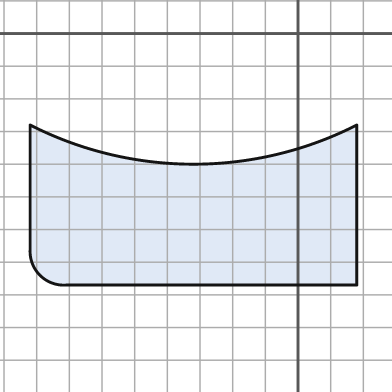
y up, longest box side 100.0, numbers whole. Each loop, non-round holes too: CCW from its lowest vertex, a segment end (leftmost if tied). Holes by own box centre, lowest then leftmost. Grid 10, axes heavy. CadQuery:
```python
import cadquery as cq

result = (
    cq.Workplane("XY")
    .moveTo(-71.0, -77.0)
    .lineTo(18.0, -77.0)
    .lineTo(18.0, -28.0)
    .threePointArc((-32.0, -40.0), (-82.0, -28.0))
    .lineTo(-82.0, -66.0)
    .threePointArc((-79.0, -74.0), (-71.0, -77.0))
    .close()
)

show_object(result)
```